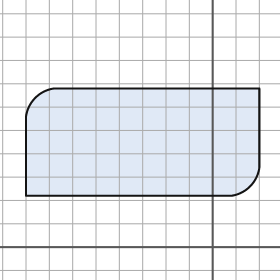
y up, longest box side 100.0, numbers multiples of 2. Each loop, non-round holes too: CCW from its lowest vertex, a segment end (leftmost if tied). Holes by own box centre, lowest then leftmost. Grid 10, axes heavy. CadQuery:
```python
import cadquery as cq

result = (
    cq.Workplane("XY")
    .moveTo(-80.0, 22.0)
    .lineTo(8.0, 22.0)
    .threePointArc((16.0, 26.0), (20.0, 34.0))
    .lineTo(20.0, 68.0)
    .lineTo(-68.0, 68.0)
    .threePointArc((-76.0, 64.0), (-80.0, 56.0))
    .close()
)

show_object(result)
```